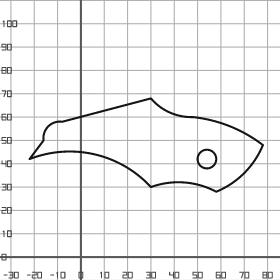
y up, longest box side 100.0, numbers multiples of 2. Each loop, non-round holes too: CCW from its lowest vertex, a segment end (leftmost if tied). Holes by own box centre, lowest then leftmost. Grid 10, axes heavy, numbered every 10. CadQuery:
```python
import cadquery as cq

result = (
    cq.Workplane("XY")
    .moveTo(58.0, 28.0)
    .threePointArc((70.0, 36.0), (78.0, 48.0))
    .threePointArc((64.0, 56.0), (48.0, 60.0))
    .threePointArc((38.0, 62.0), (30.0, 68.0))
    .lineTo(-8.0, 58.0)
    .threePointArc((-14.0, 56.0), (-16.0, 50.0))
    .lineTo(-22.0, 42.0)
    .threePointArc((6.0, 44.0), (30.0, 30.0))
    .threePointArc((44.0, 32.0), (58.0, 28.0))
    .close()
    .moveTo(54.0, 42.0)
    .circle(4.0)
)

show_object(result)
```